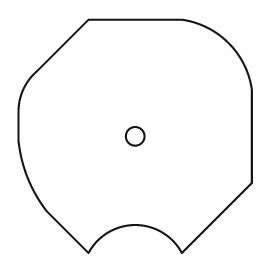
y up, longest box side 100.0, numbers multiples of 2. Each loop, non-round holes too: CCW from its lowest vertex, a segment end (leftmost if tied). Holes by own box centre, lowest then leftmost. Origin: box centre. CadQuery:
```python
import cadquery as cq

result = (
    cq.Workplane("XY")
    .moveTo(-20.0, -50.0)
    .threePointArc((0.0, -38.0), (20.0, -50.0))
    .lineTo(50.0, -20.0)
    .lineTo(50.0, 20.0)
    .threePointArc((40.0, 40.0), (20.0, 50.0))
    .lineTo(-20.0, 50.0)
    .lineTo(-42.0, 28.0)
    .threePointArc((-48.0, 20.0), (-50.0, 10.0))
    .lineTo(-50.0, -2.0)
    .threePointArc((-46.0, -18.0), (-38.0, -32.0))
    .close()
    .moveTo(0.0, 0.0)
    .circle(4.0)
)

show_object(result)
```